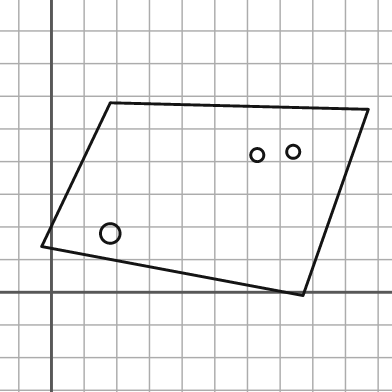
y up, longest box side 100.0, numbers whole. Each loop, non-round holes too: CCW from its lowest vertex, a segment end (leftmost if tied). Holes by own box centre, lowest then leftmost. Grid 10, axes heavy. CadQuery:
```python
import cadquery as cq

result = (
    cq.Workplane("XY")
    .moveTo(77.0, -1.0)
    .lineTo(97.0, 56.0)
    .lineTo(18.0, 58.0)
    .lineTo(-3.0, 14.0)
    .close()
    .moveTo(18.0, 18.0)
    .circle(3.0)
    .moveTo(63.0, 42.0)
    .circle(2.0)
    .moveTo(74.0, 43.0)
    .circle(2.0)
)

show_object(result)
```